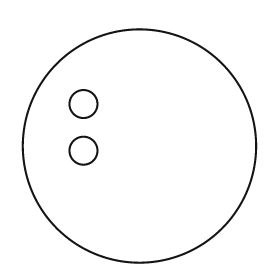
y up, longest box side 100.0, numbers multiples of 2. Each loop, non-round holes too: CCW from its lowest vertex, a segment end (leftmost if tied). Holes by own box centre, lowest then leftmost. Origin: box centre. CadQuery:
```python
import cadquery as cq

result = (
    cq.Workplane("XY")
    .moveTo(0.0, 0.0)
    .circle(50.0)
    .moveTo(-24.0, -2.0)
    .circle(6.0)
    .moveTo(-24.0, 18.0)
    .circle(6.0)
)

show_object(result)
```